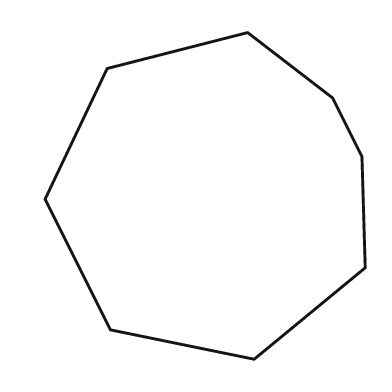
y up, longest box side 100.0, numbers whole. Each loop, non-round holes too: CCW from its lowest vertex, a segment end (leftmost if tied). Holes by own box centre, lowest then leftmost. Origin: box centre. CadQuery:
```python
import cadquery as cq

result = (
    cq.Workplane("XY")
    .moveTo(15.0, -50.0)
    .lineTo(49.0, -22.0)
    .lineTo(48.0, 12.0)
    .lineTo(39.0, 30.0)
    .lineTo(13.0, 50.0)
    .lineTo(-30.0, 39.0)
    .lineTo(-49.0, -1.0)
    .lineTo(-29.0, -41.0)
    .close()
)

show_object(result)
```